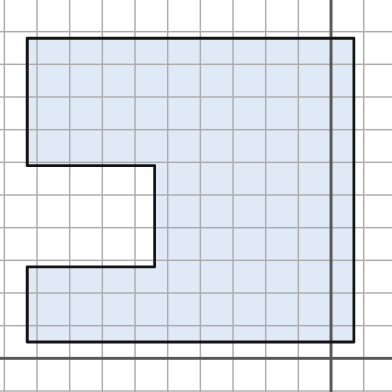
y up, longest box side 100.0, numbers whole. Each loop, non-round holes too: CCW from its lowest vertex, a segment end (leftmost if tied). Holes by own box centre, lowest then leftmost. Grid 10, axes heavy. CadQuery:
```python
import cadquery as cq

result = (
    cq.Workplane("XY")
    .moveTo(-93.0, 5.0)
    .lineTo(7.0, 5.0)
    .lineTo(7.0, 98.0)
    .lineTo(-93.0, 98.0)
    .lineTo(-93.0, 59.0)
    .lineTo(-54.0, 59.0)
    .lineTo(-54.0, 28.0)
    .lineTo(-93.0, 28.0)
    .close()
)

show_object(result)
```